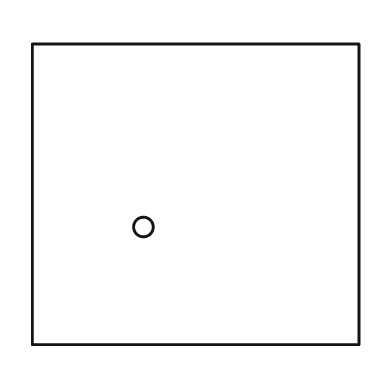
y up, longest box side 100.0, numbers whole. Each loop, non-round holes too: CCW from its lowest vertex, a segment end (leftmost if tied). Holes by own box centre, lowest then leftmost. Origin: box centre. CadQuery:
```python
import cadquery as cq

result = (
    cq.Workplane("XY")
    .moveTo(-50.0, -46.0)
    .lineTo(50.0, -46.0)
    .lineTo(50.0, 46.0)
    .lineTo(-50.0, 46.0)
    .close()
    .moveTo(-16.0, -10.0)
    .circle(3.0)
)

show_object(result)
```